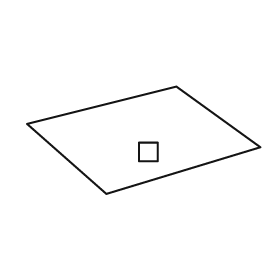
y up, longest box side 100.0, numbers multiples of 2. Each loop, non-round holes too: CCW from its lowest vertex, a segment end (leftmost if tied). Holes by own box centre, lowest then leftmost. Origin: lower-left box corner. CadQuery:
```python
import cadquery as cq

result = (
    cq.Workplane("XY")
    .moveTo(34.0, 0.0)
    .lineTo(100.0, 20.0)
    .lineTo(64.0, 46.0)
    .lineTo(0.0, 30.0)
    .close()
    .moveTo(48.0, 14.0)
    .lineTo(56.0, 14.0)
    .lineTo(56.0, 22.0)
    .lineTo(48.0, 22.0)
    .close()
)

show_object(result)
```